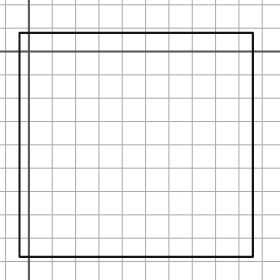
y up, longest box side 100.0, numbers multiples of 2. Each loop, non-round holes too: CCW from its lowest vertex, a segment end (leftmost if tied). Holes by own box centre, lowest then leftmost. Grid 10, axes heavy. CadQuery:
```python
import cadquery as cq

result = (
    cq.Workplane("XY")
    .moveTo(-4.0, -88.0)
    .lineTo(96.0, -88.0)
    .lineTo(96.0, 8.0)
    .lineTo(-4.0, 8.0)
    .close()
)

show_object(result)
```